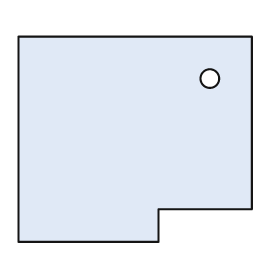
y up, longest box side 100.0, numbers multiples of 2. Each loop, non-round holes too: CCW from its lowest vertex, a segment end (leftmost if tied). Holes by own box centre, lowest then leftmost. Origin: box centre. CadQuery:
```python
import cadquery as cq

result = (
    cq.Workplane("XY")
    .moveTo(-50.0, -44.0)
    .lineTo(10.0, -44.0)
    .lineTo(10.0, -30.0)
    .lineTo(50.0, -30.0)
    .lineTo(50.0, 44.0)
    .lineTo(-50.0, 44.0)
    .close()
    .moveTo(32.0, 26.0)
    .circle(4.0)
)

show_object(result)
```